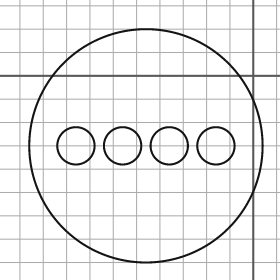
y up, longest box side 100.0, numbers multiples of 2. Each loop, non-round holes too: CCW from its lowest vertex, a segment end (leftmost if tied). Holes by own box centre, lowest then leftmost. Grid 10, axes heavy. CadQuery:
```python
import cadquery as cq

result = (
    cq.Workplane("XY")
    .moveTo(-46.0, -30.0)
    .circle(50.0)
    .moveTo(-76.0, -30.0)
    .circle(8.0)
    .moveTo(-56.0, -30.0)
    .circle(8.0)
    .moveTo(-36.0, -30.0)
    .circle(8.0)
    .moveTo(-16.0, -30.0)
    .circle(8.0)
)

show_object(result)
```